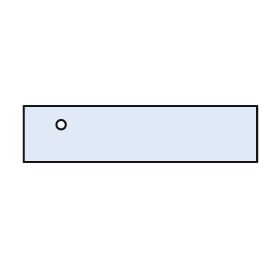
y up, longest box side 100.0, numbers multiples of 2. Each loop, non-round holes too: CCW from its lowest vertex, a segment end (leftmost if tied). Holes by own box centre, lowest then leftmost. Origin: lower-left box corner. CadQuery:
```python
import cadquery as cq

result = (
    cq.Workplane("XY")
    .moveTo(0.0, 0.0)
    .lineTo(100.0, 0.0)
    .lineTo(100.0, 24.0)
    .lineTo(0.0, 24.0)
    .close()
    .moveTo(16.0, 16.0)
    .circle(2.0)
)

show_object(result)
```